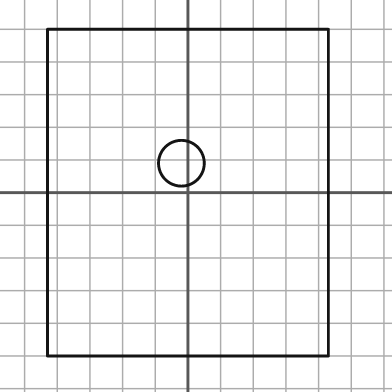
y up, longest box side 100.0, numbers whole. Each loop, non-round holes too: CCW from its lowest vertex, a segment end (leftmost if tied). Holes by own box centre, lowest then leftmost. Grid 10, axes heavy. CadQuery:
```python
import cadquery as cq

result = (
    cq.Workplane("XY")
    .moveTo(-43.0, -50.0)
    .lineTo(43.0, -50.0)
    .lineTo(43.0, 50.0)
    .lineTo(-43.0, 50.0)
    .close()
    .moveTo(-2.0, 9.0)
    .circle(7.0)
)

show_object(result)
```